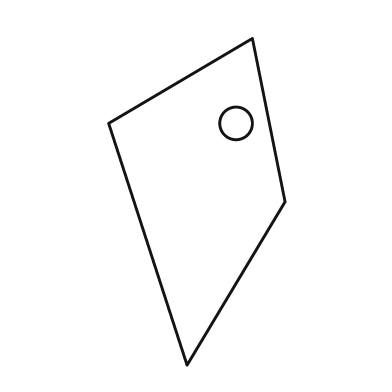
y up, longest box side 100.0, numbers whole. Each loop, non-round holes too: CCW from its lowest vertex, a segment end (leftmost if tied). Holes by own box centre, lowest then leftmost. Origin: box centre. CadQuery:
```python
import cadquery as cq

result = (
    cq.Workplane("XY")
    .moveTo(-3.0, -50.0)
    .lineTo(27.0, 0.0)
    .lineTo(17.0, 50.0)
    .lineTo(-27.0, 24.0)
    .close()
    .moveTo(12.0, 24.0)
    .circle(5.0)
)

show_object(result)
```